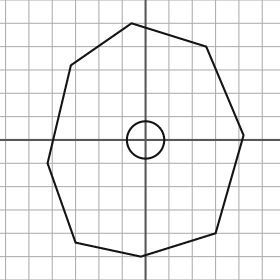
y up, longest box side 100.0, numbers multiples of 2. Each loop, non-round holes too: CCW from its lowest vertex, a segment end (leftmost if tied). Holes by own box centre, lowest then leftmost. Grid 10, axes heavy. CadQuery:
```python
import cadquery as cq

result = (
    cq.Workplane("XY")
    .moveTo(-2.0, -50.0)
    .lineTo(30.0, -40.0)
    .lineTo(42.0, 2.0)
    .lineTo(26.0, 40.0)
    .lineTo(-6.0, 50.0)
    .lineTo(-32.0, 32.0)
    .lineTo(-42.0, -10.0)
    .lineTo(-30.0, -44.0)
    .close()
    .moveTo(0.0, 0.0)
    .circle(8.0)
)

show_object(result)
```